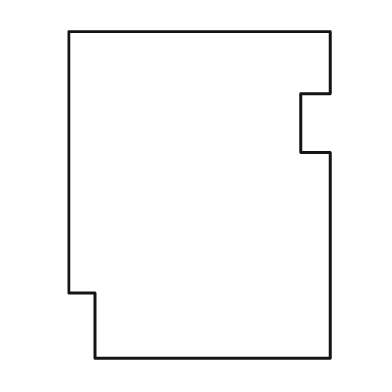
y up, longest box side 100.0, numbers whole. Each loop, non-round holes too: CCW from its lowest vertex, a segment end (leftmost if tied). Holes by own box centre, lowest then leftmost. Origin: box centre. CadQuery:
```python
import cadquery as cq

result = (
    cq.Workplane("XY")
    .moveTo(-32.0, -50.0)
    .lineTo(40.0, -50.0)
    .lineTo(40.0, 13.0)
    .lineTo(31.0, 13.0)
    .lineTo(31.0, 31.0)
    .lineTo(40.0, 31.0)
    .lineTo(40.0, 50.0)
    .lineTo(-40.0, 50.0)
    .lineTo(-40.0, -30.0)
    .lineTo(-32.0, -30.0)
    .close()
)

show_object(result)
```